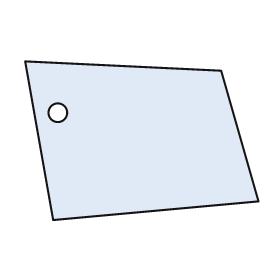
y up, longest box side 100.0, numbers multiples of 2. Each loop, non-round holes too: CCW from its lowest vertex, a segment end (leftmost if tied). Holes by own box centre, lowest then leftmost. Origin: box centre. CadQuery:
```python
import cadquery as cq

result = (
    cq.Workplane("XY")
    .moveTo(-38.0, -34.0)
    .lineTo(50.0, -26.0)
    .lineTo(34.0, 30.0)
    .lineTo(-50.0, 34.0)
    .close()
    .moveTo(-36.0, 12.0)
    .circle(4.0)
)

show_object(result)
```